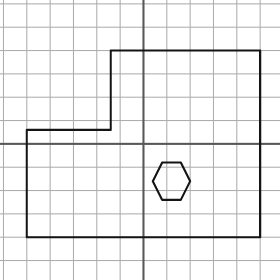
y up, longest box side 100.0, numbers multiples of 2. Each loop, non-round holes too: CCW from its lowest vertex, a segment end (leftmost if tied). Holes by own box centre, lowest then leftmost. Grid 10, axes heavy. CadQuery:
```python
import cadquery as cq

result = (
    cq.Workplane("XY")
    .moveTo(-50.0, -40.0)
    .lineTo(50.0, -40.0)
    .lineTo(50.0, 40.0)
    .lineTo(-14.0, 40.0)
    .lineTo(-14.0, 6.0)
    .lineTo(-50.0, 6.0)
    .close()
    .moveTo(8.0, -24.0)
    .lineTo(16.0, -24.0)
    .lineTo(20.0, -16.0)
    .lineTo(16.0, -8.0)
    .lineTo(8.0, -8.0)
    .lineTo(4.0, -16.0)
    .close()
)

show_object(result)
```